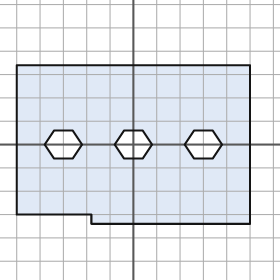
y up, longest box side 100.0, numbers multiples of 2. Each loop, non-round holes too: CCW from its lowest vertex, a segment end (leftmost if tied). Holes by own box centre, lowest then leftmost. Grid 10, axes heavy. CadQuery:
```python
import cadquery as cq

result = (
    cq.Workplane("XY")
    .moveTo(-18.0, -34.0)
    .lineTo(50.0, -34.0)
    .lineTo(50.0, 34.0)
    .lineTo(-50.0, 34.0)
    .lineTo(-50.0, -30.0)
    .lineTo(-18.0, -30.0)
    .close()
    .moveTo(-34.0, -6.0)
    .lineTo(-26.0, -6.0)
    .lineTo(-22.0, 0.0)
    .lineTo(-26.0, 6.0)
    .lineTo(-34.0, 6.0)
    .lineTo(-38.0, 0.0)
    .close()
    .moveTo(-4.0, -6.0)
    .lineTo(4.0, -6.0)
    .lineTo(8.0, 0.0)
    .lineTo(4.0, 6.0)
    .lineTo(-4.0, 6.0)
    .lineTo(-8.0, 0.0)
    .close()
    .moveTo(26.0, -6.0)
    .lineTo(34.0, -6.0)
    .lineTo(38.0, 0.0)
    .lineTo(34.0, 6.0)
    .lineTo(26.0, 6.0)
    .lineTo(22.0, 0.0)
    .close()
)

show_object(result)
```